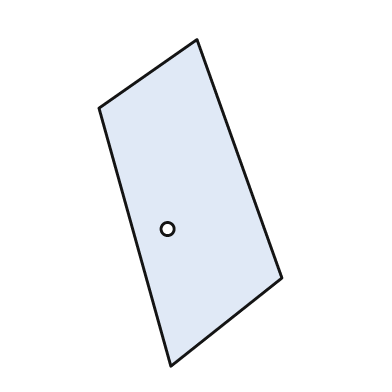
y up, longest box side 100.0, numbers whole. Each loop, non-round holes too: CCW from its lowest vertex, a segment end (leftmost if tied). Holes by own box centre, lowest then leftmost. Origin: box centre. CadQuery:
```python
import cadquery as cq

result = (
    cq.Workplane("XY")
    .moveTo(-6.0, -50.0)
    .lineTo(28.0, -23.0)
    .lineTo(2.0, 50.0)
    .lineTo(-28.0, 29.0)
    .close()
    .moveTo(-7.0, -8.0)
    .circle(2.0)
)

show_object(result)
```